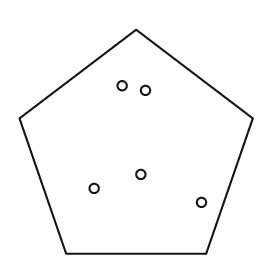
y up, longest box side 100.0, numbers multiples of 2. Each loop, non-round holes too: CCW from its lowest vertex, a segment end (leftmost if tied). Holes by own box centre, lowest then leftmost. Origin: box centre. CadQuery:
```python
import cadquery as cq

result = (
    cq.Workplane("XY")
    .moveTo(-30.0, -48.0)
    .lineTo(30.0, -48.0)
    .lineTo(50.0, 10.0)
    .lineTo(0.0, 48.0)
    .lineTo(-50.0, 10.0)
    .close()
    .moveTo(28.0, -26.0)
    .circle(2.0)
    .moveTo(-18.0, -20.0)
    .circle(2.0)
    .moveTo(2.0, -14.0)
    .circle(2.0)
    .moveTo(4.0, 22.0)
    .circle(2.0)
    .moveTo(-6.0, 24.0)
    .circle(2.0)
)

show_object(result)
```